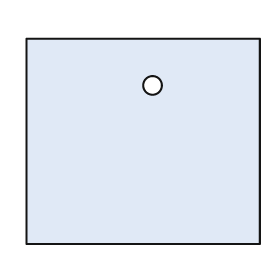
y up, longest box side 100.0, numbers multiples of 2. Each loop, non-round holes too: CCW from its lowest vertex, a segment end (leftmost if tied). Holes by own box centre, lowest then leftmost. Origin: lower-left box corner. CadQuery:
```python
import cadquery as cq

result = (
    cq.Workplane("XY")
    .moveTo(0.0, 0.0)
    .lineTo(100.0, 0.0)
    .lineTo(100.0, 88.0)
    .lineTo(0.0, 88.0)
    .close()
    .moveTo(54.0, 68.0)
    .circle(4.0)
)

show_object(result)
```